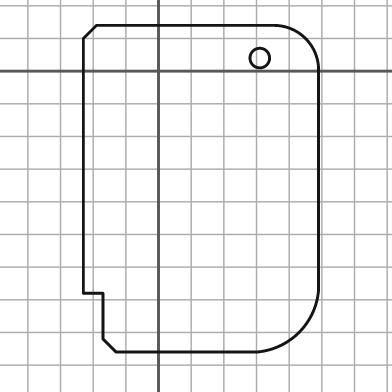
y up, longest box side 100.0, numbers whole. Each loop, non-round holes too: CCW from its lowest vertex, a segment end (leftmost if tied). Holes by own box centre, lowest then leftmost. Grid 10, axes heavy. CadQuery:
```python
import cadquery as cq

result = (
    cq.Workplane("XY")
    .moveTo(-13.0, -86.0)
    .lineTo(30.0, -86.0)
    .threePointArc((43.0, -80.0), (49.0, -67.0))
    .lineTo(49.0, 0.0)
    .threePointArc((45.0, 10.0), (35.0, 14.0))
    .lineTo(-19.0, 14.0)
    .lineTo(-23.0, 10.0)
    .lineTo(-23.0, -68.0)
    .lineTo(-17.0, -68.0)
    .lineTo(-17.0, -82.0)
    .close()
    .moveTo(31.0, 4.0)
    .circle(3.0)
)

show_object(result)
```